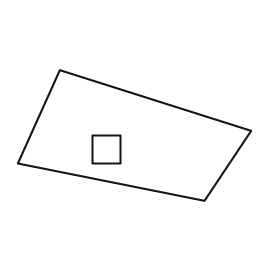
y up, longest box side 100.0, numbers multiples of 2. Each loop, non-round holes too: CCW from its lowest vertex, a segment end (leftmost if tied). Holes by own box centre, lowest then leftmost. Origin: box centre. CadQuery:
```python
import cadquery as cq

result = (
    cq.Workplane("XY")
    .moveTo(30.0, -28.0)
    .lineTo(50.0, 2.0)
    .lineTo(-32.0, 28.0)
    .lineTo(-50.0, -12.0)
    .close()
    .moveTo(-18.0, -12.0)
    .lineTo(-6.0, -12.0)
    .lineTo(-6.0, 0.0)
    .lineTo(-18.0, 0.0)
    .close()
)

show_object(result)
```